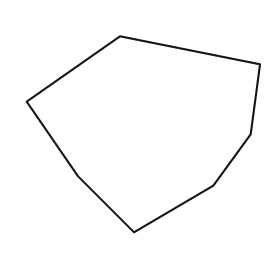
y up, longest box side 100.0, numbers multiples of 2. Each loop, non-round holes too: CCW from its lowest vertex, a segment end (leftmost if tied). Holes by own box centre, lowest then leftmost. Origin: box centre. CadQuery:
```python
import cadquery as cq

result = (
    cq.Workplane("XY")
    .moveTo(-4.0, -42.0)
    .lineTo(30.0, -22.0)
    .lineTo(46.0, 0.0)
    .lineTo(50.0, 30.0)
    .lineTo(-10.0, 42.0)
    .lineTo(-50.0, 14.0)
    .lineTo(-28.0, -18.0)
    .close()
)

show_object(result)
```